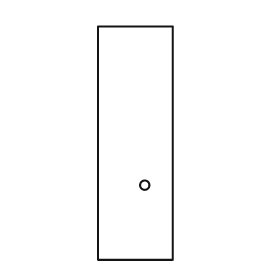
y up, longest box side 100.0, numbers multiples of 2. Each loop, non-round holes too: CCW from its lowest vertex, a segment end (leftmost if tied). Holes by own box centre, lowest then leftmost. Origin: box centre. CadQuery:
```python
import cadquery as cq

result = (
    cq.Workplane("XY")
    .moveTo(-16.0, -50.0)
    .lineTo(16.0, -50.0)
    .lineTo(16.0, 50.0)
    .lineTo(-16.0, 50.0)
    .close()
    .moveTo(4.0, -18.0)
    .circle(2.0)
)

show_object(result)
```